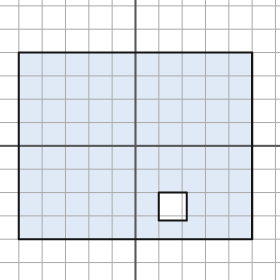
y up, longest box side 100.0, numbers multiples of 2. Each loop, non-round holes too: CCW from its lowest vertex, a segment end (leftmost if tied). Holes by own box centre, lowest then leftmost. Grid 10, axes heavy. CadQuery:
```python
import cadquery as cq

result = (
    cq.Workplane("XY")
    .moveTo(-50.0, -40.0)
    .lineTo(50.0, -40.0)
    .lineTo(50.0, 40.0)
    .lineTo(-50.0, 40.0)
    .close()
    .moveTo(10.0, -32.0)
    .lineTo(22.0, -32.0)
    .lineTo(22.0, -20.0)
    .lineTo(10.0, -20.0)
    .close()
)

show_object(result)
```